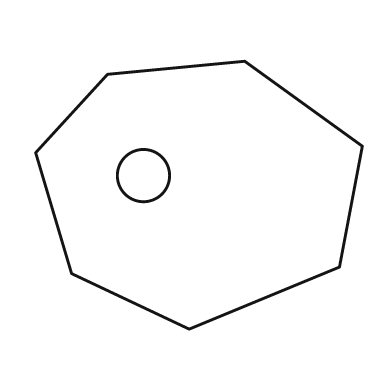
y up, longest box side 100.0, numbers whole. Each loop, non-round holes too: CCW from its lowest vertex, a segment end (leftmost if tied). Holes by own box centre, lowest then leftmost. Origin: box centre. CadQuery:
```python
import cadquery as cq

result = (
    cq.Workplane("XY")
    .moveTo(-3.0, -41.0)
    .lineTo(43.0, -22.0)
    .lineTo(50.0, 15.0)
    .lineTo(14.0, 41.0)
    .lineTo(-28.0, 37.0)
    .lineTo(-50.0, 13.0)
    .lineTo(-39.0, -24.0)
    .close()
    .moveTo(-17.0, 6.0)
    .circle(8.0)
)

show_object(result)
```